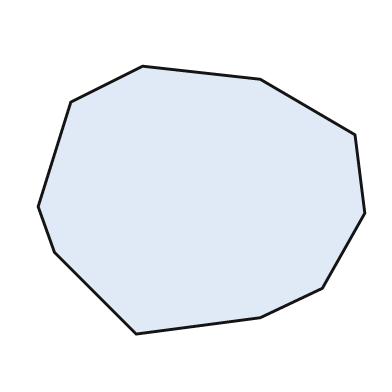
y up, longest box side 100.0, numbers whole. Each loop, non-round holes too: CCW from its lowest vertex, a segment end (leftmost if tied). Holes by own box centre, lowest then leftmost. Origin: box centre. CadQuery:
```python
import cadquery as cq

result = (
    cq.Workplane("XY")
    .moveTo(-20.0, -41.0)
    .lineTo(18.0, -36.0)
    .lineTo(37.0, -27.0)
    .lineTo(50.0, -4.0)
    .lineTo(47.0, 20.0)
    .lineTo(18.0, 37.0)
    .lineTo(-18.0, 41.0)
    .lineTo(-40.0, 30.0)
    .lineTo(-50.0, -2.0)
    .lineTo(-45.0, -16.0)
    .close()
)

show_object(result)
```